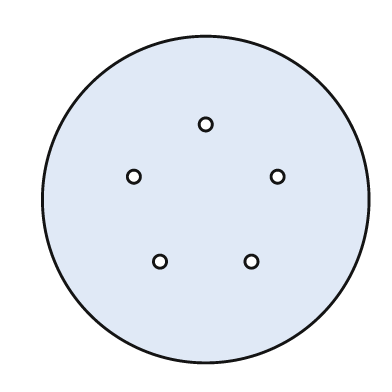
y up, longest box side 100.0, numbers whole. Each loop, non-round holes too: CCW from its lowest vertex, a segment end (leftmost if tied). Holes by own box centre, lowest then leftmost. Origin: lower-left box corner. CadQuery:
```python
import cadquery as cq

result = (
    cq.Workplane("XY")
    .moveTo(50.0, 50.0)
    .circle(50.0)
    .moveTo(36.0, 31.0)
    .circle(2.0)
    .moveTo(64.0, 31.0)
    .circle(2.0)
    .moveTo(28.0, 57.0)
    .circle(2.0)
    .moveTo(72.0, 57.0)
    .circle(2.0)
    .moveTo(50.0, 73.0)
    .circle(2.0)
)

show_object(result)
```